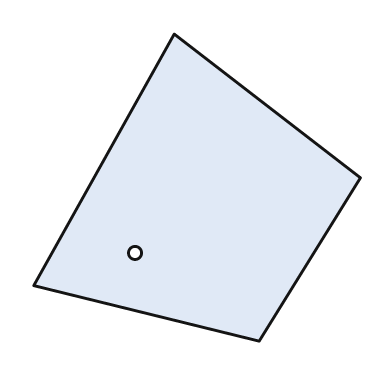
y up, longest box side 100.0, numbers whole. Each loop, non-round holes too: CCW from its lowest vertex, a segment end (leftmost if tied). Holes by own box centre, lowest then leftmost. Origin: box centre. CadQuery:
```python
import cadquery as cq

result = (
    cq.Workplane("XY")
    .moveTo(19.0, -47.0)
    .lineTo(50.0, 3.0)
    .lineTo(-7.0, 47.0)
    .lineTo(-50.0, -30.0)
    .close()
    .moveTo(-19.0, -20.0)
    .circle(2.0)
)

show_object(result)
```